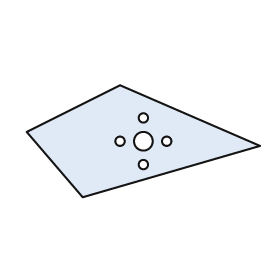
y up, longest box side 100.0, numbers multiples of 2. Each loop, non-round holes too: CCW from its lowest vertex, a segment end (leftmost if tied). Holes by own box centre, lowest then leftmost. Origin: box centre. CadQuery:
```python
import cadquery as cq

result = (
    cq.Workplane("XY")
    .moveTo(-26.0, -24.0)
    .lineTo(50.0, -2.0)
    .lineTo(-10.0, 24.0)
    .lineTo(-50.0, 4.0)
    .close()
    .moveTo(0.0, -10.0)
    .circle(2.0)
    .moveTo(-10.0, 0.0)
    .circle(2.0)
    .moveTo(0.0, 0.0)
    .circle(4.0)
    .moveTo(10.0, 0.0)
    .circle(2.0)
    .moveTo(0.0, 10.0)
    .circle(2.0)
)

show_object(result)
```